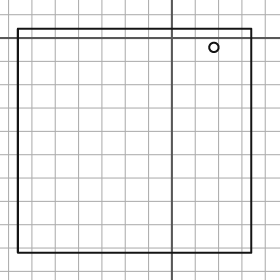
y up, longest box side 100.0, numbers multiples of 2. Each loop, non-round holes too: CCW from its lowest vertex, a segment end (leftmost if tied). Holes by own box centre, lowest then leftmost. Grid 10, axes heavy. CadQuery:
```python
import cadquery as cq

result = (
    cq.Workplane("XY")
    .moveTo(-66.0, -92.0)
    .lineTo(34.0, -92.0)
    .lineTo(34.0, 4.0)
    .lineTo(-66.0, 4.0)
    .close()
    .moveTo(18.0, -4.0)
    .circle(2.0)
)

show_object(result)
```